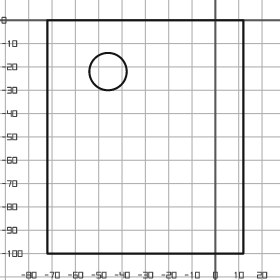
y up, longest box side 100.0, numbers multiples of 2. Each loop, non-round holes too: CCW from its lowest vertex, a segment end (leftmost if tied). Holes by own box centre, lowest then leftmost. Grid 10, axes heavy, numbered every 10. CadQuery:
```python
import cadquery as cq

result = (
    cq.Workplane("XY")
    .moveTo(-72.0, -100.0)
    .lineTo(12.0, -100.0)
    .lineTo(12.0, 0.0)
    .lineTo(-72.0, 0.0)
    .close()
    .moveTo(-46.0, -22.0)
    .circle(8.0)
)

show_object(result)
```